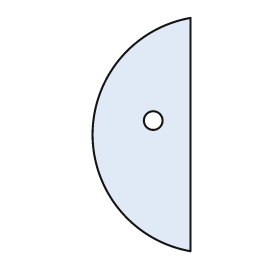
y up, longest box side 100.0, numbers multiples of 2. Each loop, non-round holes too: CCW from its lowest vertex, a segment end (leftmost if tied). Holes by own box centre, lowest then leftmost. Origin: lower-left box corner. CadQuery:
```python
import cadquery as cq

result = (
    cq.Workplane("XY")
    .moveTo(42.0, 0.0)
    .lineTo(42.0, 100.0)
    .threePointArc((0.0, 50.0), (42.0, 0.0))
    .close()
    .moveTo(26.0, 56.0)
    .circle(4.0)
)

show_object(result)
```